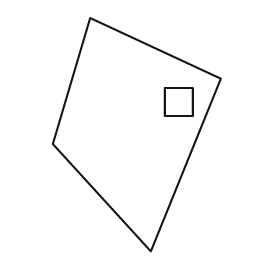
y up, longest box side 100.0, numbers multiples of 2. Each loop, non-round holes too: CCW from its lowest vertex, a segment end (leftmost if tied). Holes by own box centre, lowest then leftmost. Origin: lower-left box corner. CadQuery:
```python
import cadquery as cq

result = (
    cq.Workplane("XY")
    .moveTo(42.0, 0.0)
    .lineTo(72.0, 74.0)
    .lineTo(16.0, 100.0)
    .lineTo(0.0, 46.0)
    .close()
    .moveTo(48.0, 58.0)
    .lineTo(60.0, 58.0)
    .lineTo(60.0, 70.0)
    .lineTo(48.0, 70.0)
    .close()
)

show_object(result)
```